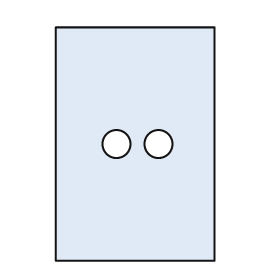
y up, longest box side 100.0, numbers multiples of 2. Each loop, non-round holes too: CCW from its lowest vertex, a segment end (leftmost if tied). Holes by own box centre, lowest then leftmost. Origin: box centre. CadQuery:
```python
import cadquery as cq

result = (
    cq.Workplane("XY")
    .moveTo(-34.0, -50.0)
    .lineTo(34.0, -50.0)
    .lineTo(34.0, 50.0)
    .lineTo(-34.0, 50.0)
    .close()
    .moveTo(-8.0, 0.0)
    .circle(6.0)
    .moveTo(10.0, 0.0)
    .circle(6.0)
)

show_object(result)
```